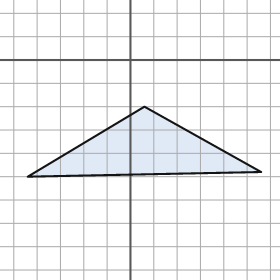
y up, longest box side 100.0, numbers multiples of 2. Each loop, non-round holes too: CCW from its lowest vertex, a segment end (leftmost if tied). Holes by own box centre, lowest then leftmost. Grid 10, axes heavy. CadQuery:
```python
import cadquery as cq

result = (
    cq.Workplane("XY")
    .moveTo(-44.0, -50.0)
    .lineTo(56.0, -48.0)
    .lineTo(6.0, -20.0)
    .close()
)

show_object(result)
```